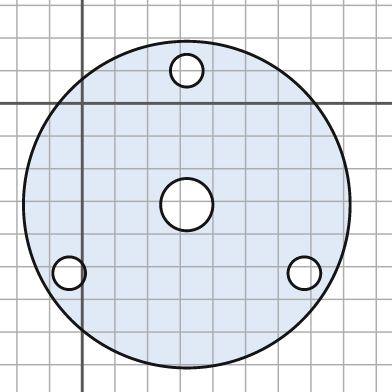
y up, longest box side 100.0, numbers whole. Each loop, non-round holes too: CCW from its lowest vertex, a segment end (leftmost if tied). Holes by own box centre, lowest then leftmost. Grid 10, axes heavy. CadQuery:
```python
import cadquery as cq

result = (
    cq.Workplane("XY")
    .moveTo(32.0, -31.0)
    .circle(50.0)
    .moveTo(-4.0, -52.0)
    .circle(5.0)
    .moveTo(68.0, -52.0)
    .circle(5.0)
    .moveTo(32.0, -31.0)
    .circle(8.0)
    .moveTo(32.0, 10.0)
    .circle(5.0)
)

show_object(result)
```